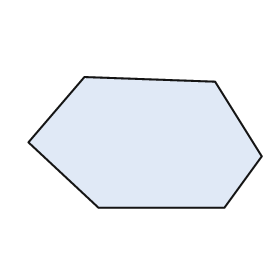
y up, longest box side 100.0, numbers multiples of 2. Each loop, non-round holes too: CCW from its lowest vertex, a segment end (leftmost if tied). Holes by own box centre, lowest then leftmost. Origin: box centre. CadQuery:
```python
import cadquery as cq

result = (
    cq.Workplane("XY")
    .moveTo(-20.0, -28.0)
    .lineTo(34.0, -28.0)
    .lineTo(50.0, -6.0)
    .lineTo(30.0, 26.0)
    .lineTo(-26.0, 28.0)
    .lineTo(-50.0, 0.0)
    .close()
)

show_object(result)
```